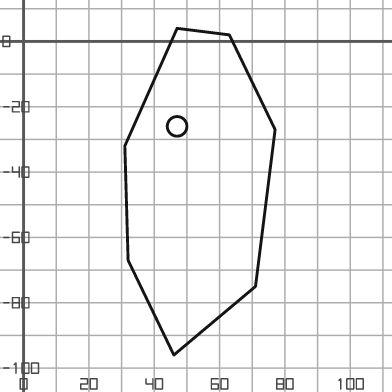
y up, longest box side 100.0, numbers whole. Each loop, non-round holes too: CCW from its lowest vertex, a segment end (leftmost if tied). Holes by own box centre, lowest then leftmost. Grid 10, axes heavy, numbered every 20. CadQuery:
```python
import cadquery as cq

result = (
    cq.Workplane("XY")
    .moveTo(46.0, -96.0)
    .lineTo(71.0, -75.0)
    .lineTo(77.0, -27.0)
    .lineTo(63.0, 2.0)
    .lineTo(47.0, 4.0)
    .lineTo(31.0, -32.0)
    .lineTo(32.0, -67.0)
    .close()
    .moveTo(47.0, -26.0)
    .circle(3.0)
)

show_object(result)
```